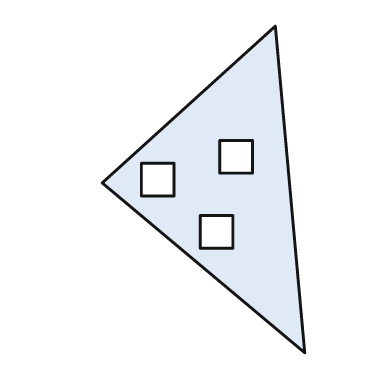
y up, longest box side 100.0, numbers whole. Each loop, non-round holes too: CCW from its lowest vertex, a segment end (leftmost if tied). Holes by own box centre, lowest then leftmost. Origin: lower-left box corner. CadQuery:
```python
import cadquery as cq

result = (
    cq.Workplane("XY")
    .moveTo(62.0, 0.0)
    .lineTo(53.0, 100.0)
    .lineTo(0.0, 52.0)
    .close()
    .moveTo(30.0, 32.0)
    .lineTo(40.0, 32.0)
    .lineTo(40.0, 42.0)
    .lineTo(30.0, 42.0)
    .close()
    .moveTo(12.0, 48.0)
    .lineTo(22.0, 48.0)
    .lineTo(22.0, 58.0)
    .lineTo(12.0, 58.0)
    .close()
    .moveTo(36.0, 55.0)
    .lineTo(46.0, 55.0)
    .lineTo(46.0, 65.0)
    .lineTo(36.0, 65.0)
    .close()
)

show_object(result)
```